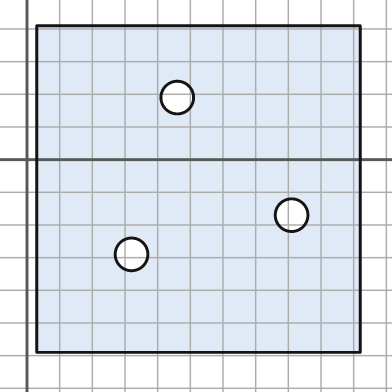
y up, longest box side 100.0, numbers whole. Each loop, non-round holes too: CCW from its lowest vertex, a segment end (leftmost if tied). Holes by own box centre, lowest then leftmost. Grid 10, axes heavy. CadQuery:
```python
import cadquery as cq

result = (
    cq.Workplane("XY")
    .moveTo(3.0, -59.0)
    .lineTo(102.0, -59.0)
    .lineTo(102.0, 41.0)
    .lineTo(3.0, 41.0)
    .close()
    .moveTo(32.0, -29.0)
    .circle(5.0)
    .moveTo(81.0, -17.0)
    .circle(5.0)
    .moveTo(46.0, 19.0)
    .circle(5.0)
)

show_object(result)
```